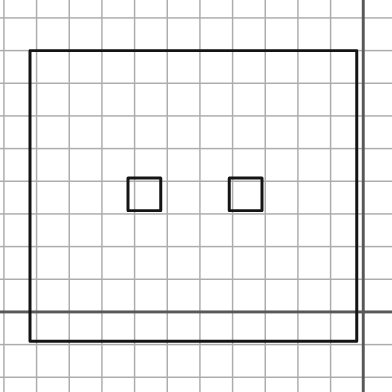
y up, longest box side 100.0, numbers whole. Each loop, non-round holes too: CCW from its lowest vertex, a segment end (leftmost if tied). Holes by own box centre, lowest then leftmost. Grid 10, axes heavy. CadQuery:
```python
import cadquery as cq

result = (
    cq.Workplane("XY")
    .moveTo(-102.0, -9.0)
    .lineTo(-2.0, -9.0)
    .lineTo(-2.0, 80.0)
    .lineTo(-102.0, 80.0)
    .close()
    .moveTo(-72.0, 31.0)
    .lineTo(-62.0, 31.0)
    .lineTo(-62.0, 41.0)
    .lineTo(-72.0, 41.0)
    .close()
    .moveTo(-41.0, 31.0)
    .lineTo(-31.0, 31.0)
    .lineTo(-31.0, 41.0)
    .lineTo(-41.0, 41.0)
    .close()
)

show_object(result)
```